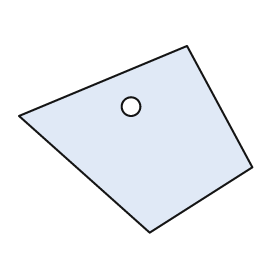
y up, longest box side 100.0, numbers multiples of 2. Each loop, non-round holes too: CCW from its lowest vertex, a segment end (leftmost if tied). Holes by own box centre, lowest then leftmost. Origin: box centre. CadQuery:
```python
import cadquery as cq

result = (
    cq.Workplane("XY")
    .moveTo(6.0, -40.0)
    .lineTo(50.0, -12.0)
    .lineTo(22.0, 40.0)
    .lineTo(-50.0, 10.0)
    .close()
    .moveTo(-2.0, 14.0)
    .circle(4.0)
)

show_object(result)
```